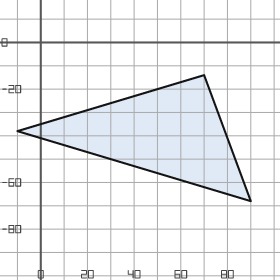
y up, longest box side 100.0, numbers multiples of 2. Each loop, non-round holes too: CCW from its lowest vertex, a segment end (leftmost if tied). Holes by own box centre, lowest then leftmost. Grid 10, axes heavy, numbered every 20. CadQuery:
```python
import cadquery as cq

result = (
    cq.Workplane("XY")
    .moveTo(90.0, -68.0)
    .lineTo(70.0, -14.0)
    .lineTo(-10.0, -38.0)
    .close()
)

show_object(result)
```